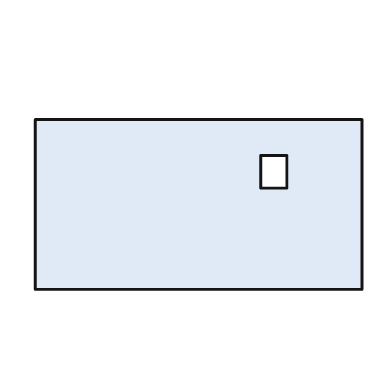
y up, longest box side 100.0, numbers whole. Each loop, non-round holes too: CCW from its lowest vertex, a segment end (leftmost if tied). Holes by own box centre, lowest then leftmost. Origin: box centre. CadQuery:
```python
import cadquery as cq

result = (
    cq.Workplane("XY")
    .moveTo(-50.0, -26.0)
    .lineTo(50.0, -26.0)
    .lineTo(50.0, 26.0)
    .lineTo(-50.0, 26.0)
    .close()
    .moveTo(19.0, 5.0)
    .lineTo(27.0, 5.0)
    .lineTo(27.0, 15.0)
    .lineTo(19.0, 15.0)
    .close()
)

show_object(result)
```